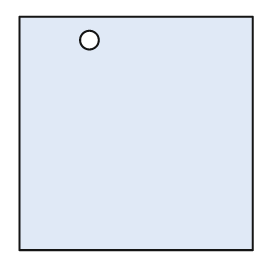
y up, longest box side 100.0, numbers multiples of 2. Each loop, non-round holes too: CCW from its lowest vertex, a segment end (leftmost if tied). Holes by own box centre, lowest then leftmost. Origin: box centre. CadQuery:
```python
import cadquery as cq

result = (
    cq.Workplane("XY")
    .moveTo(-50.0, -50.0)
    .lineTo(50.0, -50.0)
    .lineTo(50.0, 50.0)
    .lineTo(-50.0, 50.0)
    .close()
    .moveTo(-20.0, 40.0)
    .circle(4.0)
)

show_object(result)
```